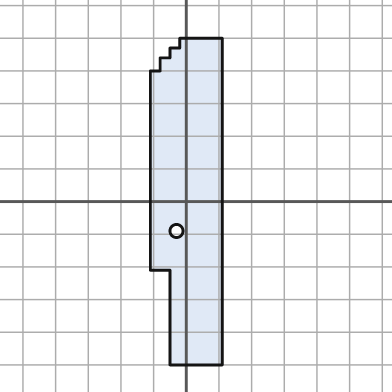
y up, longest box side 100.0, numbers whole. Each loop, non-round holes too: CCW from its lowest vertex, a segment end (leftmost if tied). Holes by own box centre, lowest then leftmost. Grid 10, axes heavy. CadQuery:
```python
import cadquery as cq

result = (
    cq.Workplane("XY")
    .moveTo(-5.0, -50.0)
    .lineTo(11.0, -50.0)
    .lineTo(11.0, 50.0)
    .lineTo(-2.0, 50.0)
    .lineTo(-2.0, 47.0)
    .lineTo(-5.0, 47.0)
    .lineTo(-5.0, 44.0)
    .lineTo(-8.0, 44.0)
    .lineTo(-8.0, 40.0)
    .lineTo(-11.0, 40.0)
    .lineTo(-11.0, -21.0)
    .lineTo(-5.0, -21.0)
    .close()
    .moveTo(-3.0, -9.0)
    .circle(2.0)
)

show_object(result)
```